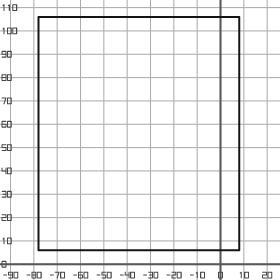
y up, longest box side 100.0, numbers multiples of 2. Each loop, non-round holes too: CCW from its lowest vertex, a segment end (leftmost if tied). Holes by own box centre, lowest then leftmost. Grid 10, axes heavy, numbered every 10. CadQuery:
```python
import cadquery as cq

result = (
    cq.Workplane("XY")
    .moveTo(-78.0, 6.0)
    .lineTo(8.0, 6.0)
    .lineTo(8.0, 106.0)
    .lineTo(-78.0, 106.0)
    .close()
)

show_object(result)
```